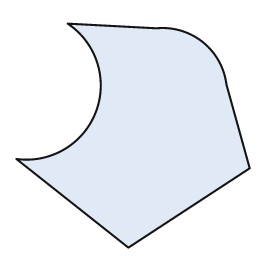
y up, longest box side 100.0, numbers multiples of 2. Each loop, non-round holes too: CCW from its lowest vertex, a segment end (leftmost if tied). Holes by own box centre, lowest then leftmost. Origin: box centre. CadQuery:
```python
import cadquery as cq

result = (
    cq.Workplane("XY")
    .moveTo(-2.0, -48.0)
    .lineTo(50.0, -14.0)
    .lineTo(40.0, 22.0)
    .threePointArc((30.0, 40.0), (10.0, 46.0))
    .lineTo(-28.0, 48.0)
    .threePointArc((-16.0, 10.0), (-50.0, -10.0))
    .close()
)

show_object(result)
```